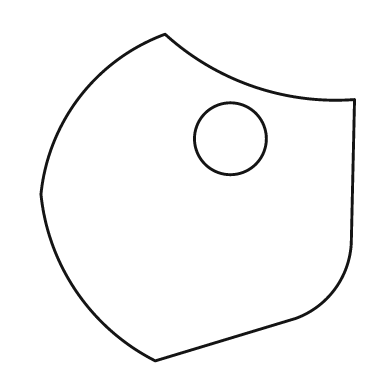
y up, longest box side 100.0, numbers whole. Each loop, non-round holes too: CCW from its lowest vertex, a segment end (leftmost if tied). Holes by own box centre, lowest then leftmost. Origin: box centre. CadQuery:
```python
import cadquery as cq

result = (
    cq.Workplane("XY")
    .moveTo(-13.0, -50.0)
    .lineTo(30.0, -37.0)
    .threePointArc((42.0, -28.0), (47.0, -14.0))
    .lineTo(48.0, 30.0)
    .threePointArc((17.0, 34.0), (-10.0, 50.0))
    .threePointArc((-36.0, 31.0), (-48.0, 1.0))
    .threePointArc((-37.0, -29.0), (-13.0, -50.0))
    .close()
    .moveTo(10.0, 18.0)
    .circle(11.0)
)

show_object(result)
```